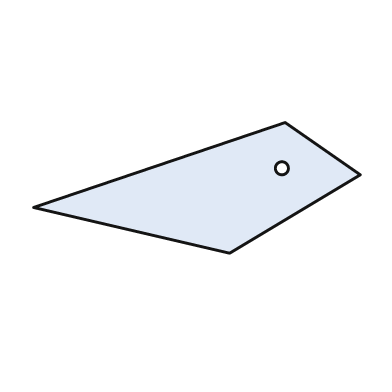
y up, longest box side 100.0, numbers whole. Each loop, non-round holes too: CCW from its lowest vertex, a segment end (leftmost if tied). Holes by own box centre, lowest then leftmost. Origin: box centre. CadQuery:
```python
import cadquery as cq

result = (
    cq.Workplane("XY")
    .moveTo(10.0, -20.0)
    .lineTo(50.0, 4.0)
    .lineTo(27.0, 20.0)
    .lineTo(-50.0, -6.0)
    .close()
    .moveTo(26.0, 6.0)
    .circle(2.0)
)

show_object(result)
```